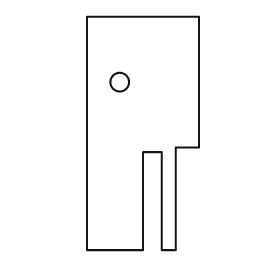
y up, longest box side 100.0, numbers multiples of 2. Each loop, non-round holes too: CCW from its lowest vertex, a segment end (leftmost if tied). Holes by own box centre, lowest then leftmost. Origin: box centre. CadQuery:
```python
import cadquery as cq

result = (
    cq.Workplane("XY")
    .moveTo(-24.0, -50.0)
    .lineTo(0.0, -50.0)
    .lineTo(0.0, -8.0)
    .lineTo(8.0, -8.0)
    .lineTo(8.0, -50.0)
    .lineTo(14.0, -50.0)
    .lineTo(14.0, -6.0)
    .lineTo(24.0, -6.0)
    .lineTo(24.0, 50.0)
    .lineTo(-24.0, 50.0)
    .close()
    .moveTo(-10.0, 22.0)
    .circle(4.0)
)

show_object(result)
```